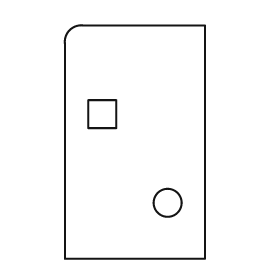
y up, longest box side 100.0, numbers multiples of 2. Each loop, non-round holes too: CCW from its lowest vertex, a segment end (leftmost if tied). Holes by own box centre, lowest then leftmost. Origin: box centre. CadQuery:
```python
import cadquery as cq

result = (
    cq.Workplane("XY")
    .moveTo(-30.0, -50.0)
    .lineTo(30.0, -50.0)
    .lineTo(30.0, 50.0)
    .lineTo(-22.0, 50.0)
    .threePointArc((-28.0, 48.0), (-30.0, 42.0))
    .close()
    .moveTo(14.0, -26.0)
    .circle(6.0)
    .moveTo(-20.0, 6.0)
    .lineTo(-8.0, 6.0)
    .lineTo(-8.0, 18.0)
    .lineTo(-20.0, 18.0)
    .close()
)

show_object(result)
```